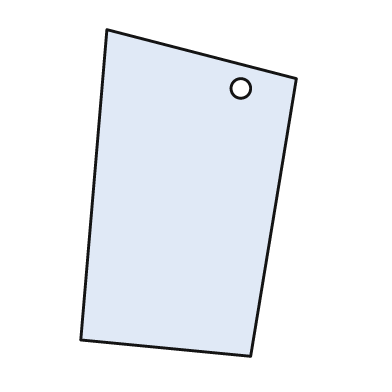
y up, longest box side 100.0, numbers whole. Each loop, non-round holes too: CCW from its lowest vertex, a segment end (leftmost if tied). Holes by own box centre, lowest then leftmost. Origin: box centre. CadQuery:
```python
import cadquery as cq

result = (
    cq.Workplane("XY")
    .moveTo(19.0, -50.0)
    .lineTo(33.0, 35.0)
    .lineTo(-25.0, 50.0)
    .lineTo(-33.0, -45.0)
    .close()
    .moveTo(16.0, 32.0)
    .circle(3.0)
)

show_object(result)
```